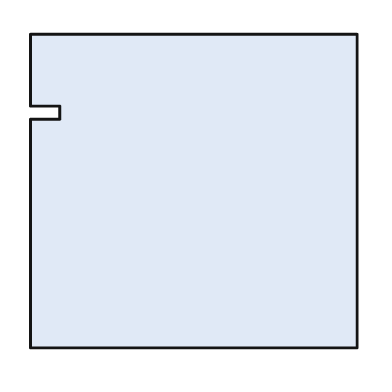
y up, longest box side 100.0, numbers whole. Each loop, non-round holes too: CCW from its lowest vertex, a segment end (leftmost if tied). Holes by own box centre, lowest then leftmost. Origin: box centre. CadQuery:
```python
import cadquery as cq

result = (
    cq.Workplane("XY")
    .moveTo(-50.0, -48.0)
    .lineTo(50.0, -48.0)
    .lineTo(50.0, 48.0)
    .lineTo(-50.0, 48.0)
    .lineTo(-50.0, 26.0)
    .lineTo(-41.0, 26.0)
    .lineTo(-41.0, 22.0)
    .lineTo(-50.0, 22.0)
    .close()
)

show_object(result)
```